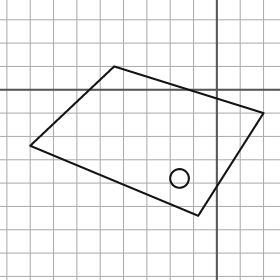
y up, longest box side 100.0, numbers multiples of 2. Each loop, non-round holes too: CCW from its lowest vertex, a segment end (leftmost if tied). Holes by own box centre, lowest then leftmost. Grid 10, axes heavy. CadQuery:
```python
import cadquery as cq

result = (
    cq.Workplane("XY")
    .moveTo(-8.0, -54.0)
    .lineTo(20.0, -10.0)
    .lineTo(-44.0, 10.0)
    .lineTo(-80.0, -24.0)
    .close()
    .moveTo(-16.0, -38.0)
    .circle(4.0)
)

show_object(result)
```